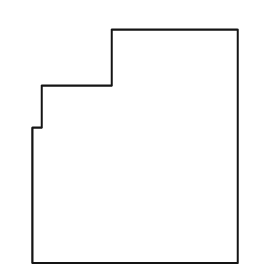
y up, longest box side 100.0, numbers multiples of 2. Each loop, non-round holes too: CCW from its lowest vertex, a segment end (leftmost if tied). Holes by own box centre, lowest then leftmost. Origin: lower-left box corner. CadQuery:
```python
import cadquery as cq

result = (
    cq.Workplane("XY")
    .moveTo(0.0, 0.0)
    .lineTo(88.0, 0.0)
    .lineTo(88.0, 100.0)
    .lineTo(34.0, 100.0)
    .lineTo(34.0, 76.0)
    .lineTo(4.0, 76.0)
    .lineTo(4.0, 58.0)
    .lineTo(0.0, 58.0)
    .close()
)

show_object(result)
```